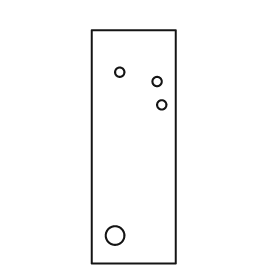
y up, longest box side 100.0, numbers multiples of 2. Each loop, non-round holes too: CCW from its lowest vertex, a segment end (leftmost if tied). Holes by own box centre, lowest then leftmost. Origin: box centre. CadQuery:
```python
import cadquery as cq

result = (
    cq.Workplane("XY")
    .moveTo(-18.0, -50.0)
    .lineTo(18.0, -50.0)
    .lineTo(18.0, 50.0)
    .lineTo(-18.0, 50.0)
    .close()
    .moveTo(-8.0, -38.0)
    .circle(4.0)
    .moveTo(12.0, 18.0)
    .circle(2.0)
    .moveTo(10.0, 28.0)
    .circle(2.0)
    .moveTo(-6.0, 32.0)
    .circle(2.0)
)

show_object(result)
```